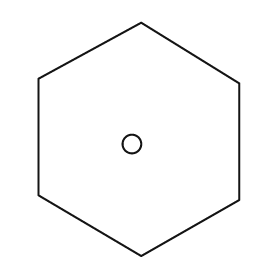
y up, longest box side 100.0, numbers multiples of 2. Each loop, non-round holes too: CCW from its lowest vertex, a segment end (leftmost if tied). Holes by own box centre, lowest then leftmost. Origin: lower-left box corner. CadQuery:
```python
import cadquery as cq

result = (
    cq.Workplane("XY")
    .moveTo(44.0, 0.0)
    .lineTo(86.0, 24.0)
    .lineTo(86.0, 74.0)
    .lineTo(44.0, 100.0)
    .lineTo(0.0, 76.0)
    .lineTo(0.0, 26.0)
    .close()
    .moveTo(40.0, 48.0)
    .circle(4.0)
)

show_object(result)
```